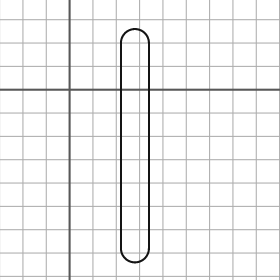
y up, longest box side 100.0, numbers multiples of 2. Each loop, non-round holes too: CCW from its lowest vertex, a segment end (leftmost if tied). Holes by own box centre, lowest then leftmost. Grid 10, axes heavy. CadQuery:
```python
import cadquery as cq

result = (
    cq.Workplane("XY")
    .moveTo(22.0, -68.0)
    .threePointArc((28.0, -74.0), (34.0, -68.0))
    .lineTo(34.0, 20.0)
    .threePointArc((28.0, 26.0), (22.0, 20.0))
    .close()
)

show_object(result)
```